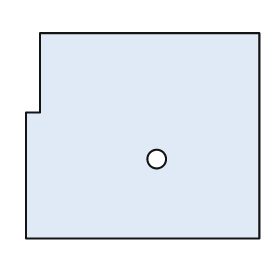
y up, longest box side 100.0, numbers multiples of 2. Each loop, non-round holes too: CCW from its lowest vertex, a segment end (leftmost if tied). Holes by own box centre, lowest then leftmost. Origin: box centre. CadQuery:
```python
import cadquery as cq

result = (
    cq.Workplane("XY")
    .moveTo(-50.0, -44.0)
    .lineTo(50.0, -44.0)
    .lineTo(50.0, 44.0)
    .lineTo(-44.0, 44.0)
    .lineTo(-44.0, 10.0)
    .lineTo(-50.0, 10.0)
    .close()
    .moveTo(6.0, -10.0)
    .circle(4.0)
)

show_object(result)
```